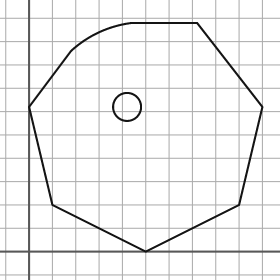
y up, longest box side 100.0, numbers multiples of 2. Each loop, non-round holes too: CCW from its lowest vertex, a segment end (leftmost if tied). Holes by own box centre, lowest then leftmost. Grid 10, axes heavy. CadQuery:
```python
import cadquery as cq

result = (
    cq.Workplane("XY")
    .moveTo(50.0, 0.0)
    .lineTo(90.0, 20.0)
    .lineTo(100.0, 62.0)
    .lineTo(72.0, 98.0)
    .lineTo(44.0, 98.0)
    .threePointArc((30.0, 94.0), (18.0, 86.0))
    .lineTo(0.0, 62.0)
    .lineTo(10.0, 20.0)
    .close()
    .moveTo(42.0, 62.0)
    .circle(6.0)
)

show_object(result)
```